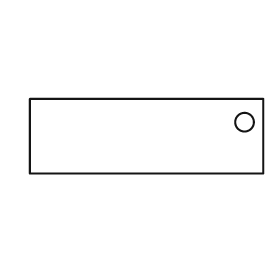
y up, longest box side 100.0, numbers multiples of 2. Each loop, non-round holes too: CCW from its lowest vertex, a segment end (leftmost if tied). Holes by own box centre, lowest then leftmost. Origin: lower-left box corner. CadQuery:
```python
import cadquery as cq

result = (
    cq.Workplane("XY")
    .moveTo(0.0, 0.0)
    .lineTo(100.0, 0.0)
    .lineTo(100.0, 32.0)
    .lineTo(0.0, 32.0)
    .close()
    .moveTo(92.0, 22.0)
    .circle(4.0)
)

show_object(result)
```